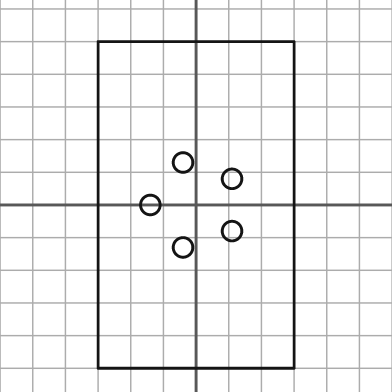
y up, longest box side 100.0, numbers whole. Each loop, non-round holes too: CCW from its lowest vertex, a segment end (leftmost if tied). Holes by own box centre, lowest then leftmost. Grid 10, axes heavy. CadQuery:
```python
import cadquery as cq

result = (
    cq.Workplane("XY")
    .moveTo(-30.0, -50.0)
    .lineTo(30.0, -50.0)
    .lineTo(30.0, 50.0)
    .lineTo(-30.0, 50.0)
    .close()
    .moveTo(-4.0, -13.0)
    .circle(3.0)
    .moveTo(11.0, -8.0)
    .circle(3.0)
    .moveTo(-14.0, 0.0)
    .circle(3.0)
    .moveTo(11.0, 8.0)
    .circle(3.0)
    .moveTo(-4.0, 13.0)
    .circle(3.0)
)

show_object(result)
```